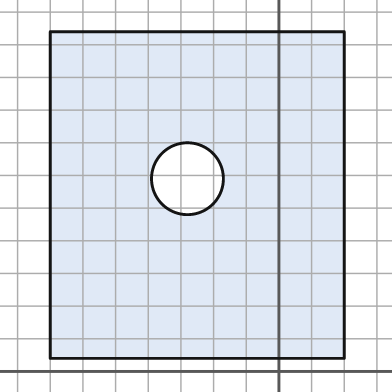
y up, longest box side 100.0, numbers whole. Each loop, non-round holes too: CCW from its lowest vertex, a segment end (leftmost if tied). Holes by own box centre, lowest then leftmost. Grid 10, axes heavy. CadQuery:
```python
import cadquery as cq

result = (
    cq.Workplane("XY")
    .moveTo(-70.0, 4.0)
    .lineTo(20.0, 4.0)
    .lineTo(20.0, 104.0)
    .lineTo(-70.0, 104.0)
    .close()
    .moveTo(-28.0, 59.0)
    .circle(11.0)
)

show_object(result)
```